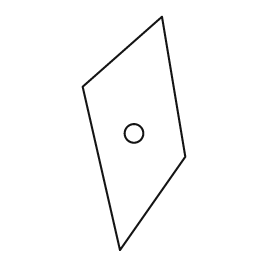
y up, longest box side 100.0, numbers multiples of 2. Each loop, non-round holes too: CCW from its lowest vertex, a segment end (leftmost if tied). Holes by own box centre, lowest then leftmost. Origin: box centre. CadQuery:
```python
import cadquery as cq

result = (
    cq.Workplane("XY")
    .moveTo(-6.0, -50.0)
    .lineTo(22.0, -10.0)
    .lineTo(12.0, 50.0)
    .lineTo(-22.0, 20.0)
    .close()
    .moveTo(0.0, 0.0)
    .circle(4.0)
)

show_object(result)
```